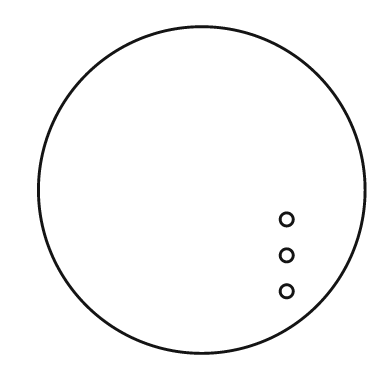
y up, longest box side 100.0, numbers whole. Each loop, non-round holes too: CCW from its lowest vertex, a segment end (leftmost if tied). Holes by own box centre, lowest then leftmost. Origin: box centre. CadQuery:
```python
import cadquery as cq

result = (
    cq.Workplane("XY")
    .moveTo(0.0, 0.0)
    .circle(50.0)
    .moveTo(26.0, -31.0)
    .circle(2.0)
    .moveTo(26.0, -20.0)
    .circle(2.0)
    .moveTo(26.0, -9.0)
    .circle(2.0)
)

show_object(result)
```